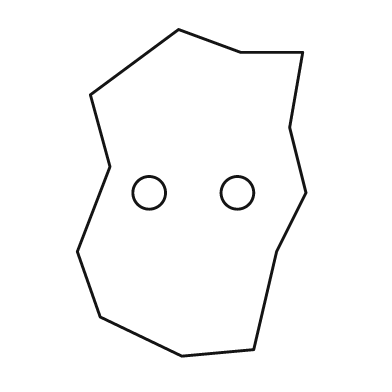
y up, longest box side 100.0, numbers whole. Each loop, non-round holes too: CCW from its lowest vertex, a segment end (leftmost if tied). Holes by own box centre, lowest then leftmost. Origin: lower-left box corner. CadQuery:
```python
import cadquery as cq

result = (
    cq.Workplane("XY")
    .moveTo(32.0, 0.0)
    .lineTo(54.0, 2.0)
    .lineTo(61.0, 32.0)
    .lineTo(70.0, 50.0)
    .lineTo(65.0, 70.0)
    .lineTo(69.0, 93.0)
    .lineTo(50.0, 93.0)
    .lineTo(31.0, 100.0)
    .lineTo(4.0, 80.0)
    .lineTo(10.0, 58.0)
    .lineTo(0.0, 32.0)
    .lineTo(7.0, 12.0)
    .close()
    .moveTo(22.0, 50.0)
    .circle(5.0)
    .moveTo(49.0, 50.0)
    .circle(5.0)
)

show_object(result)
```